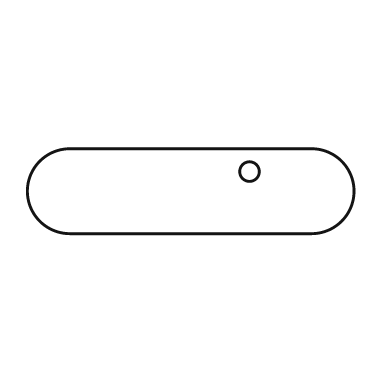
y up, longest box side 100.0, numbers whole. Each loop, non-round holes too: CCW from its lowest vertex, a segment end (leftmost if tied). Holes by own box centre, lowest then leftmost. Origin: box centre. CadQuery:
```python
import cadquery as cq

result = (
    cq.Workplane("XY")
    .moveTo(-37.0, -13.0)
    .lineTo(37.0, -13.0)
    .threePointArc((50.0, 0.0), (37.0, 13.0))
    .lineTo(-37.0, 13.0)
    .threePointArc((-50.0, 0.0), (-37.0, -13.0))
    .close()
    .moveTo(18.0, 6.0)
    .circle(3.0)
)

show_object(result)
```